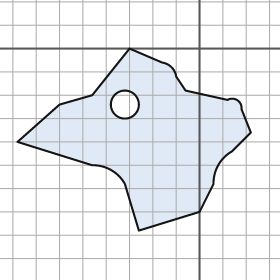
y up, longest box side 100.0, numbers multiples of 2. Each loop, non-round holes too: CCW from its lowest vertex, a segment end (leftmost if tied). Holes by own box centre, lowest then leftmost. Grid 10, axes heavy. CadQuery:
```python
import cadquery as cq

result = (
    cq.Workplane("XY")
    .moveTo(-26.0, -78.0)
    .lineTo(0.0, -70.0)
    .lineTo(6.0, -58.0)
    .threePointArc((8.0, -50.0), (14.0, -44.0))
    .lineTo(22.0, -36.0)
    .lineTo(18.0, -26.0)
    .threePointArc((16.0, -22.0), (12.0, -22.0))
    .lineTo(-6.0, -18.0)
    .lineTo(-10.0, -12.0)
    .threePointArc((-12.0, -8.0), (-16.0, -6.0))
    .lineTo(-30.0, 0.0)
    .lineTo(-46.0, -20.0)
    .lineTo(-60.0, -24.0)
    .lineTo(-78.0, -40.0)
    .lineTo(-46.0, -50.0)
    .threePointArc((-38.0, -52.0), (-32.0, -58.0))
    .close()
    .moveTo(-32.0, -24.0)
    .circle(6.0)
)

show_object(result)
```